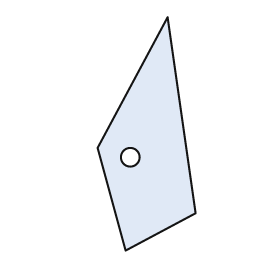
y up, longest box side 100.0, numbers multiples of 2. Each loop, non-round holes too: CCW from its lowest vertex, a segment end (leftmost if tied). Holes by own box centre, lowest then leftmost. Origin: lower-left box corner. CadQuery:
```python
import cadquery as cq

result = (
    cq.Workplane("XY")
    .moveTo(12.0, 0.0)
    .lineTo(42.0, 16.0)
    .lineTo(30.0, 100.0)
    .lineTo(0.0, 44.0)
    .close()
    .moveTo(14.0, 40.0)
    .circle(4.0)
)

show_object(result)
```